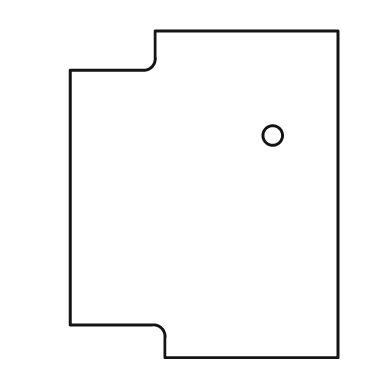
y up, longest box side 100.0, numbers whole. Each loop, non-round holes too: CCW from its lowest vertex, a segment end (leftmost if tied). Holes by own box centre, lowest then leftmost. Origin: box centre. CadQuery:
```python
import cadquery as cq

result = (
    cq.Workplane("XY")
    .moveTo(-12.0, -50.0)
    .lineTo(41.0, -50.0)
    .lineTo(41.0, 50.0)
    .lineTo(-15.0, 50.0)
    .lineTo(-15.0, 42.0)
    .threePointArc((-16.0, 39.0), (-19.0, 38.0))
    .lineTo(-41.0, 38.0)
    .lineTo(-41.0, -40.0)
    .lineTo(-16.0, -40.0)
    .threePointArc((-13.0, -41.0), (-12.0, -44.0))
    .close()
    .moveTo(21.0, 18.0)
    .circle(3.0)
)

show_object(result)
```